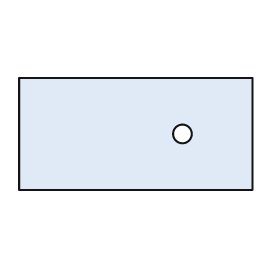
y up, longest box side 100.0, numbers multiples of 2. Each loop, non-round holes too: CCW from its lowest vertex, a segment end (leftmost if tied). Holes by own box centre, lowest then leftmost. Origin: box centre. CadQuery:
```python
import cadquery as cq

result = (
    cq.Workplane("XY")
    .moveTo(-50.0, -24.0)
    .lineTo(50.0, -24.0)
    .lineTo(50.0, 24.0)
    .lineTo(-50.0, 24.0)
    .close()
    .moveTo(20.0, 0.0)
    .circle(4.0)
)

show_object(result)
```